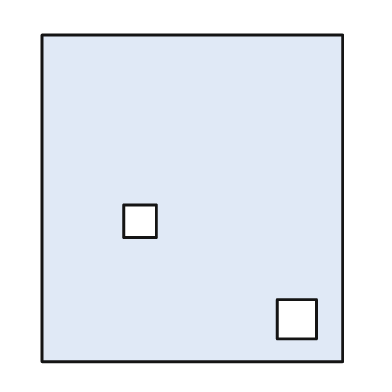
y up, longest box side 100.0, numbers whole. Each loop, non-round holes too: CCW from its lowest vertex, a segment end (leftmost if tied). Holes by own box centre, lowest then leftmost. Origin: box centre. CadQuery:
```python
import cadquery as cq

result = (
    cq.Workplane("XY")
    .moveTo(-46.0, -50.0)
    .lineTo(46.0, -50.0)
    .lineTo(46.0, 50.0)
    .lineTo(-46.0, 50.0)
    .close()
    .moveTo(26.0, -43.0)
    .lineTo(38.0, -43.0)
    .lineTo(38.0, -31.0)
    .lineTo(26.0, -31.0)
    .close()
    .moveTo(-21.0, -12.0)
    .lineTo(-11.0, -12.0)
    .lineTo(-11.0, -2.0)
    .lineTo(-21.0, -2.0)
    .close()
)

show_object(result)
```